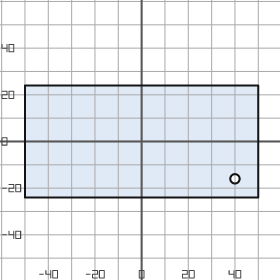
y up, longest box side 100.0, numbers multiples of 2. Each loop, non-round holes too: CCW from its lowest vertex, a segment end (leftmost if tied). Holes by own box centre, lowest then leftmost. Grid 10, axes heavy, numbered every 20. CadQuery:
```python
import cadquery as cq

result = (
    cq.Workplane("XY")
    .moveTo(-50.0, -24.0)
    .lineTo(50.0, -24.0)
    .lineTo(50.0, 24.0)
    .lineTo(-50.0, 24.0)
    .close()
    .moveTo(40.0, -16.0)
    .circle(2.0)
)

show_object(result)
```